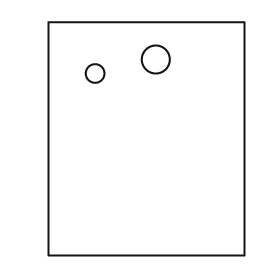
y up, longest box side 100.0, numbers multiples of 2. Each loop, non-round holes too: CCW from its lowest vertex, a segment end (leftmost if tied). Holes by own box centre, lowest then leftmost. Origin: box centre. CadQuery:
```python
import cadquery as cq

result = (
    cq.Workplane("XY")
    .moveTo(-42.0, -50.0)
    .lineTo(42.0, -50.0)
    .lineTo(42.0, 50.0)
    .lineTo(-42.0, 50.0)
    .close()
    .moveTo(-22.0, 28.0)
    .circle(4.0)
    .moveTo(4.0, 34.0)
    .circle(6.0)
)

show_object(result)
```